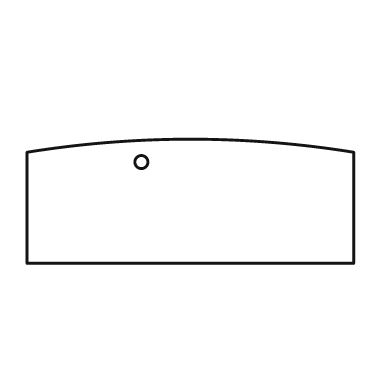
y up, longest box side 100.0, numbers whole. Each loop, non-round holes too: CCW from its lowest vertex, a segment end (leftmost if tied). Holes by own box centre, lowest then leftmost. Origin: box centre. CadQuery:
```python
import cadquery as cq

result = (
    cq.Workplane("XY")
    .moveTo(-50.0, -19.0)
    .lineTo(50.0, -19.0)
    .lineTo(50.0, 15.0)
    .threePointArc((0.0, 19.0), (-50.0, 15.0))
    .close()
    .moveTo(-15.0, 12.0)
    .circle(2.0)
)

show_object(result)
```